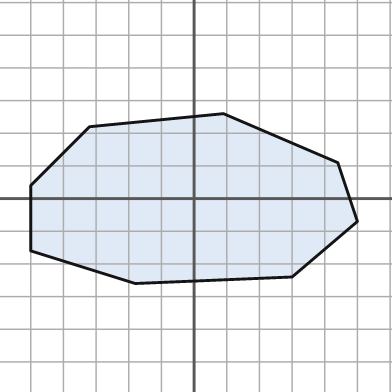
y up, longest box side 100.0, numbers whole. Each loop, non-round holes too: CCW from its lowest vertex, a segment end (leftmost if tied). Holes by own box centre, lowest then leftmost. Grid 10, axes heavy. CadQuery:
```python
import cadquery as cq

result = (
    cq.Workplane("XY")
    .moveTo(-18.0, -26.0)
    .lineTo(30.0, -24.0)
    .lineTo(50.0, -7.0)
    .lineTo(44.0, 11.0)
    .lineTo(9.0, 26.0)
    .lineTo(-32.0, 22.0)
    .lineTo(-50.0, 4.0)
    .lineTo(-50.0, -16.0)
    .close()
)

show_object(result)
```